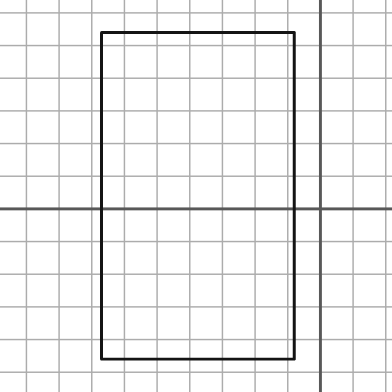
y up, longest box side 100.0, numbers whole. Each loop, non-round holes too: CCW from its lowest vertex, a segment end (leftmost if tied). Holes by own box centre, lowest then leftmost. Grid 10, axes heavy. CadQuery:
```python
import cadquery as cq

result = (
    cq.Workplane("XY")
    .moveTo(-67.0, -46.0)
    .lineTo(-8.0, -46.0)
    .lineTo(-8.0, 54.0)
    .lineTo(-67.0, 54.0)
    .close()
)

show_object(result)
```